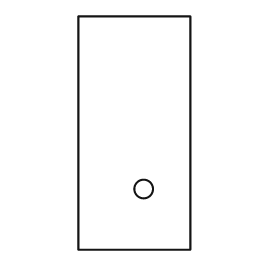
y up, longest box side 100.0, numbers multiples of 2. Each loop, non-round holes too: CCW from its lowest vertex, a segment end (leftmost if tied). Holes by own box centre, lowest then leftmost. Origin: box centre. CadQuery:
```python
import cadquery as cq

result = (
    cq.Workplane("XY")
    .moveTo(-24.0, -50.0)
    .lineTo(24.0, -50.0)
    .lineTo(24.0, 50.0)
    .lineTo(-24.0, 50.0)
    .close()
    .moveTo(4.0, -24.0)
    .circle(4.0)
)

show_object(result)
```